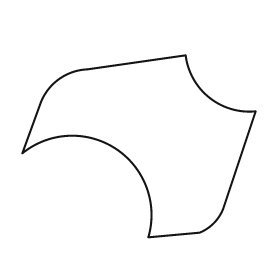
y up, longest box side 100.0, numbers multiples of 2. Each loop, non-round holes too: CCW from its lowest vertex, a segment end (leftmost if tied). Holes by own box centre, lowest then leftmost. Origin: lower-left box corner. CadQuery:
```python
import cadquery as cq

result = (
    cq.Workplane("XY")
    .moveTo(54.0, 0.0)
    .lineTo(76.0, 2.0)
    .threePointArc((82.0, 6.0), (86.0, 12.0))
    .lineTo(100.0, 54.0)
    .threePointArc((80.0, 60.0), (70.0, 78.0))
    .lineTo(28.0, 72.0)
    .threePointArc((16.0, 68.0), (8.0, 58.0))
    .lineTo(0.0, 36.0)
    .threePointArc((40.0, 38.0), (54.0, 0.0))
    .close()
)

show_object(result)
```